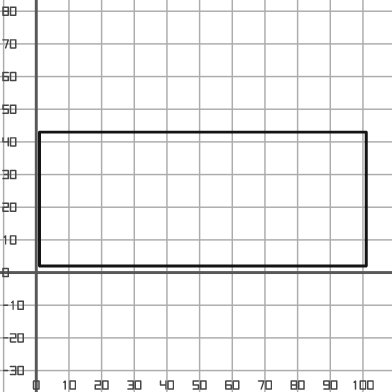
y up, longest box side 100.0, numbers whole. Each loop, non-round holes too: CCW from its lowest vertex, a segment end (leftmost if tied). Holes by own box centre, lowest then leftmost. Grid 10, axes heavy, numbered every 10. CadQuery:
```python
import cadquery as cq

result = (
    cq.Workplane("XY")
    .moveTo(1.0, 2.0)
    .lineTo(101.0, 2.0)
    .lineTo(101.0, 43.0)
    .lineTo(1.0, 43.0)
    .close()
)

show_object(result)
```